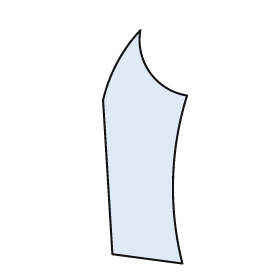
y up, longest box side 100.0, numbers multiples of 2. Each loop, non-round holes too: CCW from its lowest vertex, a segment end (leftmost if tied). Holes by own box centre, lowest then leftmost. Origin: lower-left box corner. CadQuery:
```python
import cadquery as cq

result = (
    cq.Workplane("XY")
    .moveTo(34.0, 0.0)
    .threePointArc((30.0, 36.0), (36.0, 72.0))
    .threePointArc((20.0, 82.0), (16.0, 100.0))
    .threePointArc((6.0, 86.0), (0.0, 70.0))
    .lineTo(4.0, 4.0)
    .close()
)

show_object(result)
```